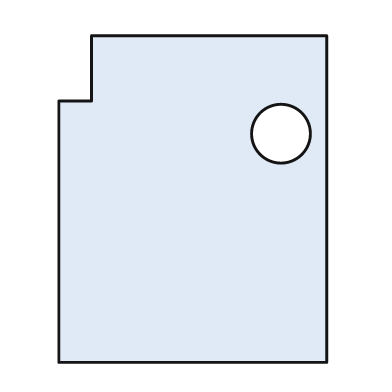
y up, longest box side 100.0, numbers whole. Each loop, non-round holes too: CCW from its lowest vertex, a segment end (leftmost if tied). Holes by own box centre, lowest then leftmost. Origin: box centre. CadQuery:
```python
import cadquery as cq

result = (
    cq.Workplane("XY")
    .moveTo(-41.0, -50.0)
    .lineTo(41.0, -50.0)
    .lineTo(41.0, 50.0)
    .lineTo(-31.0, 50.0)
    .lineTo(-31.0, 30.0)
    .lineTo(-41.0, 30.0)
    .close()
    .moveTo(27.0, 20.0)
    .circle(9.0)
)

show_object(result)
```